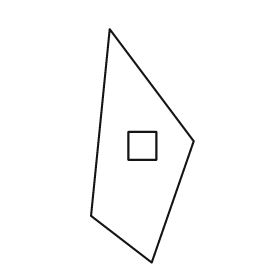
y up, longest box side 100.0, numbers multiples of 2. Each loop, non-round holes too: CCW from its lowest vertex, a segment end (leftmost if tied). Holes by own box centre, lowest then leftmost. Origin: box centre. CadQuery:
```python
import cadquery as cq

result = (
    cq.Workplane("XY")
    .moveTo(4.0, -50.0)
    .lineTo(22.0, 2.0)
    .lineTo(-14.0, 50.0)
    .lineTo(-22.0, -30.0)
    .close()
    .moveTo(-6.0, -6.0)
    .lineTo(6.0, -6.0)
    .lineTo(6.0, 6.0)
    .lineTo(-6.0, 6.0)
    .close()
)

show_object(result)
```